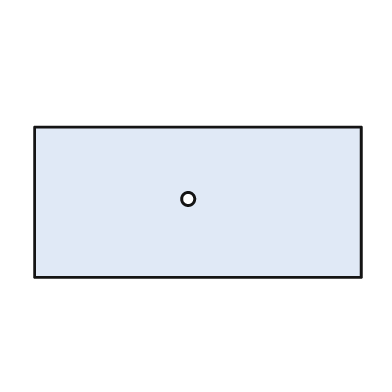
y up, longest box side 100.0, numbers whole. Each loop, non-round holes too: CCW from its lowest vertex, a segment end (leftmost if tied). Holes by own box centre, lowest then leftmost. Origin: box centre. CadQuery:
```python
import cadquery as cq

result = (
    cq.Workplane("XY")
    .moveTo(-50.0, -23.0)
    .lineTo(50.0, -23.0)
    .lineTo(50.0, 23.0)
    .lineTo(-50.0, 23.0)
    .close()
    .moveTo(-3.0, 1.0)
    .circle(2.0)
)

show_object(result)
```